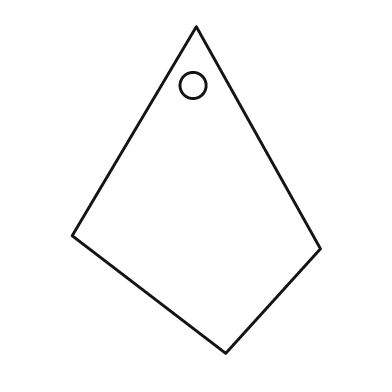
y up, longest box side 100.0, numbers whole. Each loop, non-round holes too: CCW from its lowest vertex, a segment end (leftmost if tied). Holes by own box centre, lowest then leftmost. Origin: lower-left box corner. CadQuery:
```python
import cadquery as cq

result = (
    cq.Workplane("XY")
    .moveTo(47.0, 0.0)
    .lineTo(76.0, 32.0)
    .lineTo(38.0, 100.0)
    .lineTo(0.0, 36.0)
    .close()
    .moveTo(37.0, 82.0)
    .circle(4.0)
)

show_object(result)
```